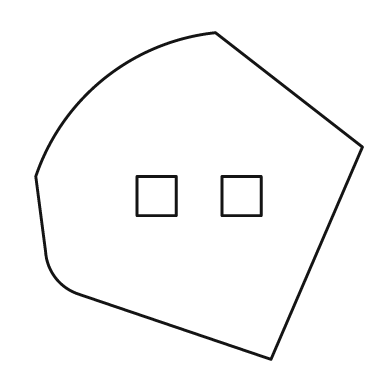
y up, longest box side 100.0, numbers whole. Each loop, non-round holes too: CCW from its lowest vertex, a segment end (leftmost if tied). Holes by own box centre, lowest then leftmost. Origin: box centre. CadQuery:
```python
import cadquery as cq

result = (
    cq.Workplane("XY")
    .moveTo(22.0, -50.0)
    .lineTo(50.0, 15.0)
    .lineTo(5.0, 50.0)
    .threePointArc((-29.0, 36.0), (-50.0, 6.0))
    .lineTo(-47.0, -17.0)
    .threePointArc((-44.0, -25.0), (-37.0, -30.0))
    .close()
    .moveTo(-19.0, -6.0)
    .lineTo(-7.0, -6.0)
    .lineTo(-7.0, 6.0)
    .lineTo(-19.0, 6.0)
    .close()
    .moveTo(7.0, -6.0)
    .lineTo(19.0, -6.0)
    .lineTo(19.0, 6.0)
    .lineTo(7.0, 6.0)
    .close()
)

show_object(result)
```